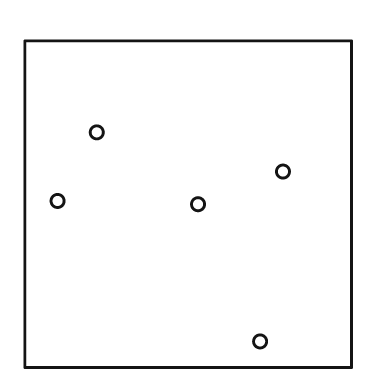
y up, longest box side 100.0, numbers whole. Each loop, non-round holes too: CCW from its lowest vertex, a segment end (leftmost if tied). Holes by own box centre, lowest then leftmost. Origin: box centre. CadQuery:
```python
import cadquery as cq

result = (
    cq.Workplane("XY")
    .moveTo(-50.0, -50.0)
    .lineTo(50.0, -50.0)
    .lineTo(50.0, 50.0)
    .lineTo(-50.0, 50.0)
    .close()
    .moveTo(22.0, -42.0)
    .circle(2.0)
    .moveTo(3.0, 0.0)
    .circle(2.0)
    .moveTo(-40.0, 1.0)
    .circle(2.0)
    .moveTo(29.0, 10.0)
    .circle(2.0)
    .moveTo(-28.0, 22.0)
    .circle(2.0)
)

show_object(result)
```